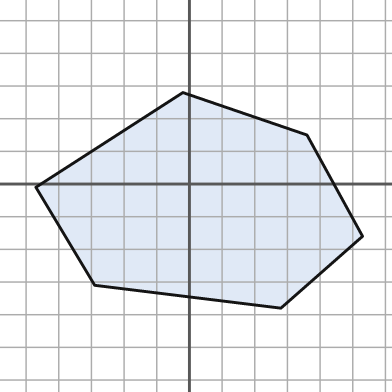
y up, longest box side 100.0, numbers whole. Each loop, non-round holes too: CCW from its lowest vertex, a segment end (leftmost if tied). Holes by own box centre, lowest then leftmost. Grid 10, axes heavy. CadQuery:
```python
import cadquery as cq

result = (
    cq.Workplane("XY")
    .moveTo(28.0, -38.0)
    .lineTo(53.0, -16.0)
    .lineTo(36.0, 15.0)
    .lineTo(-2.0, 28.0)
    .lineTo(-47.0, -1.0)
    .lineTo(-29.0, -31.0)
    .close()
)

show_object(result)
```